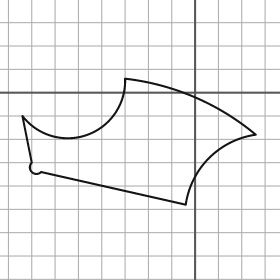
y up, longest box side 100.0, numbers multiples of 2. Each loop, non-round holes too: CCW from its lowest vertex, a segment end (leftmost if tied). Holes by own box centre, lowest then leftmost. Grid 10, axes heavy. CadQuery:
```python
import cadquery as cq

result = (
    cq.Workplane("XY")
    .moveTo(-4.0, -48.0)
    .threePointArc((6.0, -28.0), (26.0, -18.0))
    .threePointArc((0.0, -2.0), (-30.0, 6.0))
    .threePointArc((-46.0, -18.0), (-74.0, -10.0))
    .lineTo(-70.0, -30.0)
    .threePointArc((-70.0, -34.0), (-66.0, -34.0))
    .close()
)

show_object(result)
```